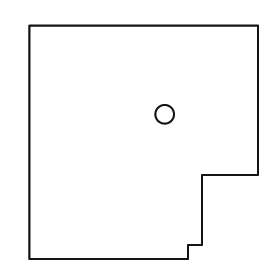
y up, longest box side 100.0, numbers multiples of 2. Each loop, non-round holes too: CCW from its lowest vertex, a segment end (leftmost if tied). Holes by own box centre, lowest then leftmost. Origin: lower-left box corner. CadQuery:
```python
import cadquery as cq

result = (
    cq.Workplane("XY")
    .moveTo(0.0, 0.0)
    .lineTo(68.0, 0.0)
    .lineTo(68.0, 6.0)
    .lineTo(74.0, 6.0)
    .lineTo(74.0, 36.0)
    .lineTo(98.0, 36.0)
    .lineTo(98.0, 100.0)
    .lineTo(0.0, 100.0)
    .close()
    .moveTo(58.0, 62.0)
    .circle(4.0)
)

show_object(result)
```